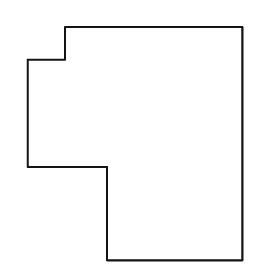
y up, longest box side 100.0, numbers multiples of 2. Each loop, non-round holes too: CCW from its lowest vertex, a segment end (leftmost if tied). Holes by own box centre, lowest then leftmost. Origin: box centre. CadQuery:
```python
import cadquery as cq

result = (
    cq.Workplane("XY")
    .moveTo(-12.0, -50.0)
    .lineTo(46.0, -50.0)
    .lineTo(46.0, 50.0)
    .lineTo(-30.0, 50.0)
    .lineTo(-30.0, 36.0)
    .lineTo(-46.0, 36.0)
    .lineTo(-46.0, -10.0)
    .lineTo(-12.0, -10.0)
    .close()
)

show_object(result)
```